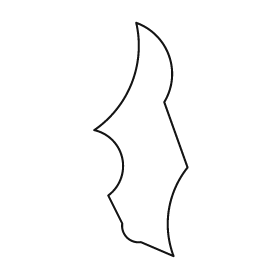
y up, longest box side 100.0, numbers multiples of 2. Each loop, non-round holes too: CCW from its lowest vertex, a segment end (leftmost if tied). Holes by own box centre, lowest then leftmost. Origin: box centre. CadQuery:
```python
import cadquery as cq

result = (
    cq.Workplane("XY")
    .moveTo(14.0, -50.0)
    .threePointArc((12.0, -30.0), (20.0, -12.0))
    .lineTo(10.0, 16.0)
    .threePointArc((12.0, 36.0), (-2.0, 50.0))
    .threePointArc((-4.0, 24.0), (-20.0, 4.0))
    .threePointArc((-8.0, -8.0), (-14.0, -24.0))
    .lineTo(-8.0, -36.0)
    .threePointArc((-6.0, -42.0), (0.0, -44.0))
    .close()
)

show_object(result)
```